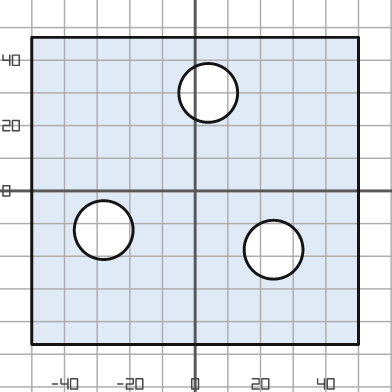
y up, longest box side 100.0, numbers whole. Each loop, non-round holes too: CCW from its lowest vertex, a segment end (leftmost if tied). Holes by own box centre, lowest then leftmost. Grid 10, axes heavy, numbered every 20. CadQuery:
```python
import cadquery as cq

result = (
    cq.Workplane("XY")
    .moveTo(-50.0, -47.0)
    .lineTo(50.0, -47.0)
    .lineTo(50.0, 47.0)
    .lineTo(-50.0, 47.0)
    .close()
    .moveTo(24.0, -18.0)
    .circle(9.0)
    .moveTo(-28.0, -12.0)
    .circle(9.0)
    .moveTo(4.0, 30.0)
    .circle(9.0)
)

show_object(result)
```